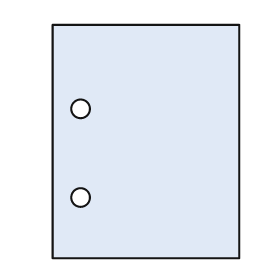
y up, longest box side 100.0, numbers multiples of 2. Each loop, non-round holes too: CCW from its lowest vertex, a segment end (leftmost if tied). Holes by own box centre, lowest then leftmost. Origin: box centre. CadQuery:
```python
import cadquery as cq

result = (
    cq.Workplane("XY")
    .moveTo(-40.0, -50.0)
    .lineTo(40.0, -50.0)
    .lineTo(40.0, 50.0)
    .lineTo(-40.0, 50.0)
    .close()
    .moveTo(-28.0, -24.0)
    .circle(4.0)
    .moveTo(-28.0, 14.0)
    .circle(4.0)
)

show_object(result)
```